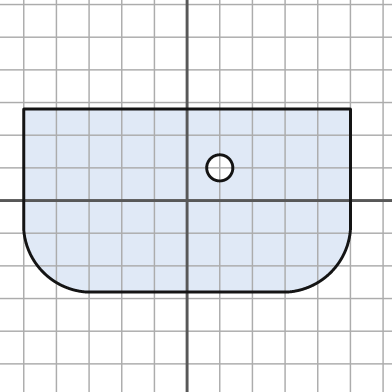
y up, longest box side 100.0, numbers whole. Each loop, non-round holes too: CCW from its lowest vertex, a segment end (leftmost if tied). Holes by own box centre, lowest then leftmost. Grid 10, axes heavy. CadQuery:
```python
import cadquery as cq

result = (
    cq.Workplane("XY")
    .moveTo(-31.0, -28.0)
    .lineTo(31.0, -28.0)
    .threePointArc((44.0, -22.0), (50.0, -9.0))
    .lineTo(50.0, 28.0)
    .lineTo(-50.0, 28.0)
    .lineTo(-50.0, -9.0)
    .threePointArc((-44.0, -22.0), (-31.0, -28.0))
    .close()
    .moveTo(10.0, 10.0)
    .circle(4.0)
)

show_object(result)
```